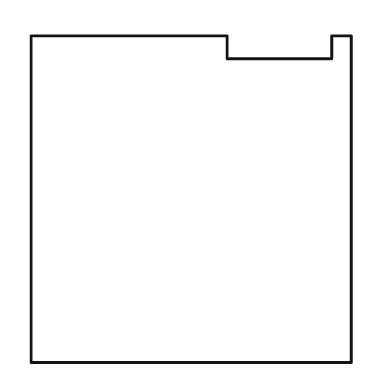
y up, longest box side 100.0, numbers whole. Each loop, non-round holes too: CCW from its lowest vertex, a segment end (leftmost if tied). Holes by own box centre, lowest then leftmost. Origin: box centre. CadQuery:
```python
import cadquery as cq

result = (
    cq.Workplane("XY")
    .moveTo(-49.0, -50.0)
    .lineTo(49.0, -50.0)
    .lineTo(49.0, 50.0)
    .lineTo(43.0, 50.0)
    .lineTo(43.0, 43.0)
    .lineTo(11.0, 43.0)
    .lineTo(11.0, 50.0)
    .lineTo(-49.0, 50.0)
    .close()
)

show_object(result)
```